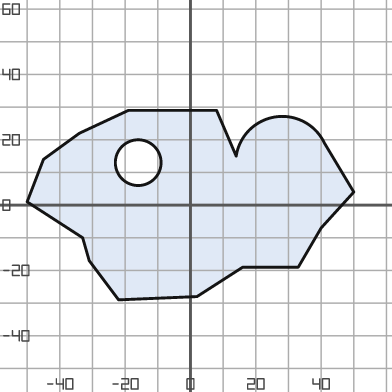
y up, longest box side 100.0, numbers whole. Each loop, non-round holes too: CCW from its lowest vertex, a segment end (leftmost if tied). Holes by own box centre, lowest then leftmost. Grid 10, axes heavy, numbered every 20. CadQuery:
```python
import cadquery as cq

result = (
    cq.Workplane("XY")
    .moveTo(-22.0, -29.0)
    .lineTo(2.0, -28.0)
    .lineTo(16.0, -19.0)
    .lineTo(33.0, -19.0)
    .lineTo(40.0, -7.0)
    .lineTo(50.0, 4.0)
    .lineTo(41.0, 19.0)
    .threePointArc((26.0, 27.0), (14.0, 15.0))
    .lineTo(8.0, 29.0)
    .lineTo(-19.0, 29.0)
    .lineTo(-34.0, 22.0)
    .lineTo(-45.0, 14.0)
    .lineTo(-50.0, 1.0)
    .lineTo(-33.0, -10.0)
    .lineTo(-31.0, -17.0)
    .close()
    .moveTo(-16.0, 13.0)
    .circle(7.0)
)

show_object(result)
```